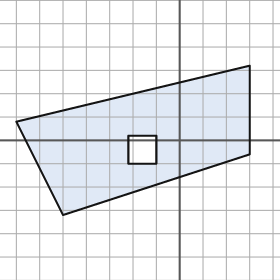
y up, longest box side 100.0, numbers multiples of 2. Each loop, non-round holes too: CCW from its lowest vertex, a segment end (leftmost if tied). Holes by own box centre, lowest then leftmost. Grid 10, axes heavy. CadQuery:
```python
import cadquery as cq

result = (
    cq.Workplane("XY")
    .moveTo(-50.0, -32.0)
    .lineTo(30.0, -6.0)
    .lineTo(30.0, 32.0)
    .lineTo(-70.0, 8.0)
    .close()
    .moveTo(-22.0, -10.0)
    .lineTo(-10.0, -10.0)
    .lineTo(-10.0, 2.0)
    .lineTo(-22.0, 2.0)
    .close()
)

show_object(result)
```